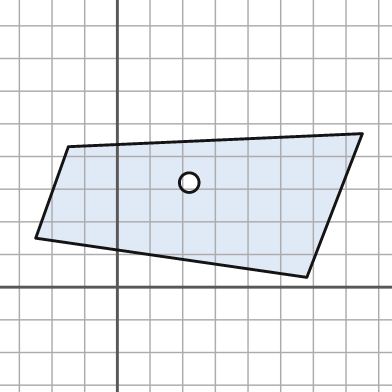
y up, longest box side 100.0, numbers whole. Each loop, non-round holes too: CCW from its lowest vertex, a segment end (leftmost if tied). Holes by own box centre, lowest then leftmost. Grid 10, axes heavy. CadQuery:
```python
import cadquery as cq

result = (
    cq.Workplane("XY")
    .moveTo(58.0, 3.0)
    .lineTo(75.0, 47.0)
    .lineTo(-15.0, 43.0)
    .lineTo(-25.0, 15.0)
    .close()
    .moveTo(22.0, 32.0)
    .circle(3.0)
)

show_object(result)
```